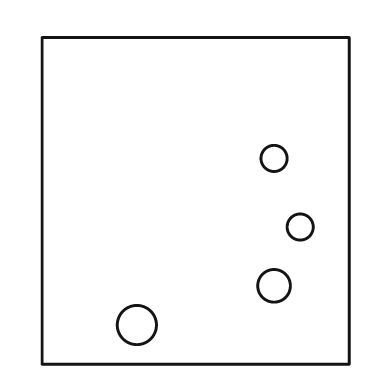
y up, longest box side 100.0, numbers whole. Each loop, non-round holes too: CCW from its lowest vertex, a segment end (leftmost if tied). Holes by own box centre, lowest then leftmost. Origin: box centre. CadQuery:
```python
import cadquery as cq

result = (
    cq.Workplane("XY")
    .moveTo(-47.0, -50.0)
    .lineTo(47.0, -50.0)
    .lineTo(47.0, 50.0)
    .lineTo(-47.0, 50.0)
    .close()
    .moveTo(-18.0, -38.0)
    .circle(6.0)
    .moveTo(24.0, -26.0)
    .circle(5.0)
    .moveTo(32.0, -8.0)
    .circle(4.0)
    .moveTo(24.0, 13.0)
    .circle(4.0)
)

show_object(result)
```